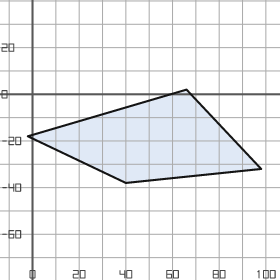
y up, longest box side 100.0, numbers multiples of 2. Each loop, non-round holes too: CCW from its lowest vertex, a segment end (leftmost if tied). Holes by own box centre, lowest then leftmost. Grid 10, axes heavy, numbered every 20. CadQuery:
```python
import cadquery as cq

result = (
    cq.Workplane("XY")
    .moveTo(40.0, -38.0)
    .lineTo(98.0, -32.0)
    .lineTo(66.0, 2.0)
    .lineTo(-2.0, -18.0)
    .close()
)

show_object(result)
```